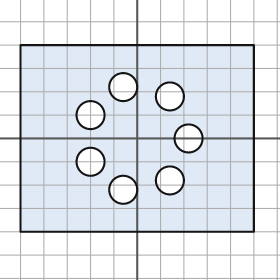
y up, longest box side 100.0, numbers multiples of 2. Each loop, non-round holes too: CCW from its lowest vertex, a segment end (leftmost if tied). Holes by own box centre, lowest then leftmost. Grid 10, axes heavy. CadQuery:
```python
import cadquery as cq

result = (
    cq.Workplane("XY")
    .moveTo(-50.0, -40.0)
    .lineTo(50.0, -40.0)
    .lineTo(50.0, 40.0)
    .lineTo(-50.0, 40.0)
    .close()
    .moveTo(-6.0, -22.0)
    .circle(6.0)
    .moveTo(14.0, -18.0)
    .circle(6.0)
    .moveTo(-20.0, -10.0)
    .circle(6.0)
    .moveTo(22.0, 0.0)
    .circle(6.0)
    .moveTo(-20.0, 10.0)
    .circle(6.0)
    .moveTo(14.0, 18.0)
    .circle(6.0)
    .moveTo(-6.0, 22.0)
    .circle(6.0)
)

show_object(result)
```